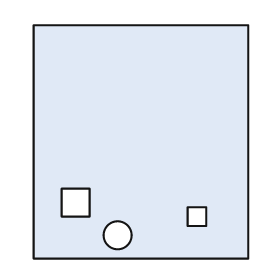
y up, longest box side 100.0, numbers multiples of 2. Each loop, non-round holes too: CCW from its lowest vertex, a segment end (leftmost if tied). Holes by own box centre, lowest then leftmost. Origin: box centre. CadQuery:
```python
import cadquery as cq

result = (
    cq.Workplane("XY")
    .moveTo(-46.0, -50.0)
    .lineTo(46.0, -50.0)
    .lineTo(46.0, 50.0)
    .lineTo(-46.0, 50.0)
    .close()
    .moveTo(-10.0, -40.0)
    .circle(6.0)
    .moveTo(20.0, -36.0)
    .lineTo(28.0, -36.0)
    .lineTo(28.0, -28.0)
    .lineTo(20.0, -28.0)
    .close()
    .moveTo(-34.0, -32.0)
    .lineTo(-22.0, -32.0)
    .lineTo(-22.0, -20.0)
    .lineTo(-34.0, -20.0)
    .close()
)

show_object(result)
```